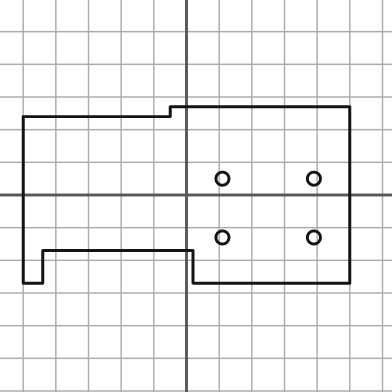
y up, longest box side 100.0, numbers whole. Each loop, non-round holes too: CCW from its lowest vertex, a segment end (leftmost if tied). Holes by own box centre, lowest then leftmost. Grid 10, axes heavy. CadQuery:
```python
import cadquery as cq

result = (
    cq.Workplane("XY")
    .moveTo(-50.0, -27.0)
    .lineTo(-44.0, -27.0)
    .lineTo(-44.0, -17.0)
    .lineTo(2.0, -17.0)
    .lineTo(2.0, -27.0)
    .lineTo(50.0, -27.0)
    .lineTo(50.0, 27.0)
    .lineTo(-5.0, 27.0)
    .lineTo(-5.0, 24.0)
    .lineTo(-50.0, 24.0)
    .close()
    .moveTo(11.0, -13.0)
    .circle(2.0)
    .moveTo(39.0, -13.0)
    .circle(2.0)
    .moveTo(11.0, 5.0)
    .circle(2.0)
    .moveTo(39.0, 5.0)
    .circle(2.0)
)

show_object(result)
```